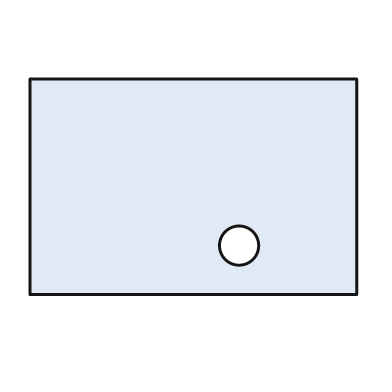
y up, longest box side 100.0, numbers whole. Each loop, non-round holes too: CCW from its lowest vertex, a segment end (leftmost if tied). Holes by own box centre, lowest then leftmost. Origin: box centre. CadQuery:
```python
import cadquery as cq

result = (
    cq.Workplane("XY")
    .moveTo(-50.0, -33.0)
    .lineTo(50.0, -33.0)
    .lineTo(50.0, 33.0)
    .lineTo(-50.0, 33.0)
    .close()
    .moveTo(14.0, -18.0)
    .circle(6.0)
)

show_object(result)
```